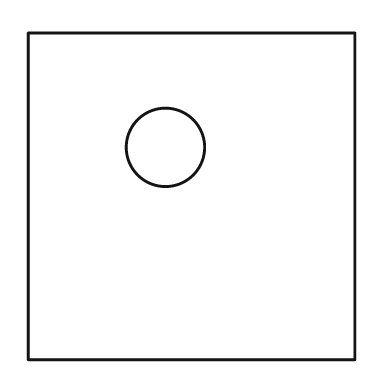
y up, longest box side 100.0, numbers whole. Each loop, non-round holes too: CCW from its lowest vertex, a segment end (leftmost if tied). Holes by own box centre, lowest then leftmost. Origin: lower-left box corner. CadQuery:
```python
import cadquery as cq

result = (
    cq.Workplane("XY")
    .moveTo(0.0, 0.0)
    .lineTo(100.0, 0.0)
    .lineTo(100.0, 100.0)
    .lineTo(0.0, 100.0)
    .close()
    .moveTo(42.0, 65.0)
    .circle(12.0)
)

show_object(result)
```